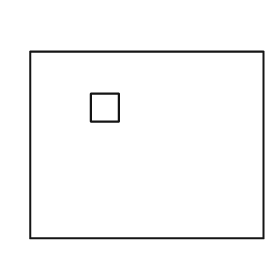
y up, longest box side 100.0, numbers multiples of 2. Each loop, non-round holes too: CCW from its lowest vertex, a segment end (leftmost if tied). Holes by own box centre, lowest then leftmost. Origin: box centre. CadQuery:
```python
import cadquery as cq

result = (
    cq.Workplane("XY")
    .moveTo(-50.0, -40.0)
    .lineTo(50.0, -40.0)
    .lineTo(50.0, 40.0)
    .lineTo(-50.0, 40.0)
    .close()
    .moveTo(-24.0, 10.0)
    .lineTo(-12.0, 10.0)
    .lineTo(-12.0, 22.0)
    .lineTo(-24.0, 22.0)
    .close()
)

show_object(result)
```